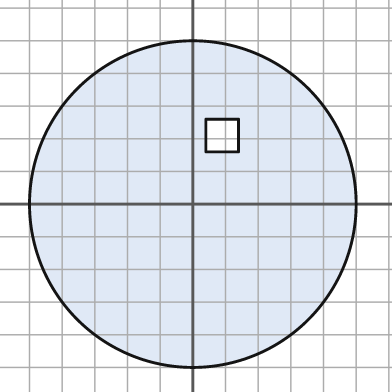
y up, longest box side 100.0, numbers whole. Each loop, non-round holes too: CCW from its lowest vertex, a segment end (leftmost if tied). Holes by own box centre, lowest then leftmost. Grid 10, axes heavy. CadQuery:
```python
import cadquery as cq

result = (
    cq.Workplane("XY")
    .moveTo(0.0, 0.0)
    .circle(50.0)
    .moveTo(4.0, 16.0)
    .lineTo(14.0, 16.0)
    .lineTo(14.0, 26.0)
    .lineTo(4.0, 26.0)
    .close()
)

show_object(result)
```